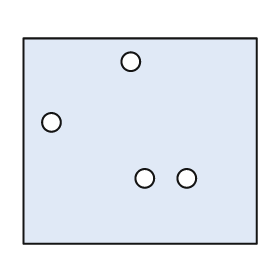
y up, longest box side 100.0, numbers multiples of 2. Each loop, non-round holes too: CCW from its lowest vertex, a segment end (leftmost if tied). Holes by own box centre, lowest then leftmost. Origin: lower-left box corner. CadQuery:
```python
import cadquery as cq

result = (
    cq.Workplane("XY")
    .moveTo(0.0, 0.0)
    .lineTo(100.0, 0.0)
    .lineTo(100.0, 88.0)
    .lineTo(0.0, 88.0)
    .close()
    .moveTo(52.0, 28.0)
    .circle(4.0)
    .moveTo(70.0, 28.0)
    .circle(4.0)
    .moveTo(12.0, 52.0)
    .circle(4.0)
    .moveTo(46.0, 78.0)
    .circle(4.0)
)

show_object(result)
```